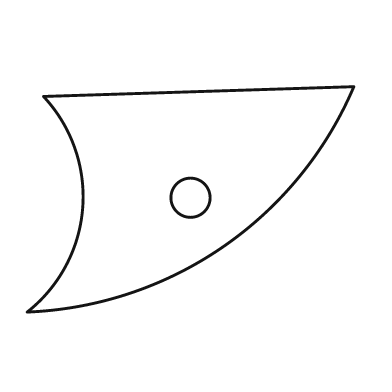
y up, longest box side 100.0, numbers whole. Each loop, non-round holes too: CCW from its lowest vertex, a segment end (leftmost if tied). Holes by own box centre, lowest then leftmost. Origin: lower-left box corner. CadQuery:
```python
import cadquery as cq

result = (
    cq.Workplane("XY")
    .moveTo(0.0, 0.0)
    .threePointArc((60.0, 20.0), (100.0, 69.0))
    .lineTo(5.0, 66.0)
    .threePointArc((17.0, 32.0), (0.0, 0.0))
    .close()
    .moveTo(50.0, 35.0)
    .circle(6.0)
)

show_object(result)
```